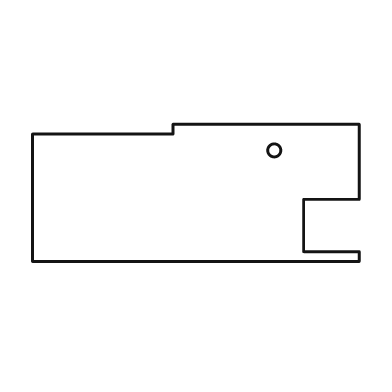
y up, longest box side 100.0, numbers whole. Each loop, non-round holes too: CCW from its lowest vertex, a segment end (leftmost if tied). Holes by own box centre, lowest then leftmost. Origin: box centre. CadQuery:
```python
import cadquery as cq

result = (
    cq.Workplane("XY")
    .moveTo(-50.0, -21.0)
    .lineTo(50.0, -21.0)
    .lineTo(50.0, -18.0)
    .lineTo(33.0, -18.0)
    .lineTo(33.0, -2.0)
    .lineTo(50.0, -2.0)
    .lineTo(50.0, 21.0)
    .lineTo(-7.0, 21.0)
    .lineTo(-7.0, 18.0)
    .lineTo(-50.0, 18.0)
    .close()
    .moveTo(24.0, 13.0)
    .circle(2.0)
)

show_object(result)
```